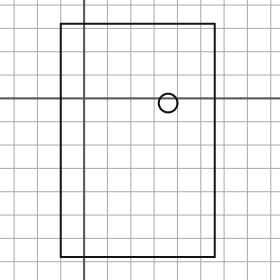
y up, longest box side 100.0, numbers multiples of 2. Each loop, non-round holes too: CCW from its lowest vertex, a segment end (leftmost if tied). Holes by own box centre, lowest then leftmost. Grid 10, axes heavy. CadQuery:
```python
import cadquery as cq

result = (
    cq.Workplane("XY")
    .moveTo(-10.0, -68.0)
    .lineTo(56.0, -68.0)
    .lineTo(56.0, 32.0)
    .lineTo(-10.0, 32.0)
    .close()
    .moveTo(36.0, -2.0)
    .circle(4.0)
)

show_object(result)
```